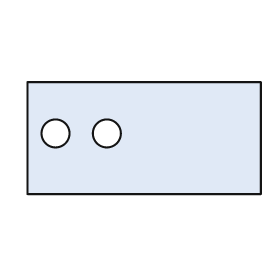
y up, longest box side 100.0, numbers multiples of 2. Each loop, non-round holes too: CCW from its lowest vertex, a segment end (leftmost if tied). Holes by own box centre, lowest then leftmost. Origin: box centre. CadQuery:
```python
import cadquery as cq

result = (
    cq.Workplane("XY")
    .moveTo(-50.0, -24.0)
    .lineTo(50.0, -24.0)
    .lineTo(50.0, 24.0)
    .lineTo(-50.0, 24.0)
    .close()
    .moveTo(-38.0, 2.0)
    .circle(6.0)
    .moveTo(-16.0, 2.0)
    .circle(6.0)
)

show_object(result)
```